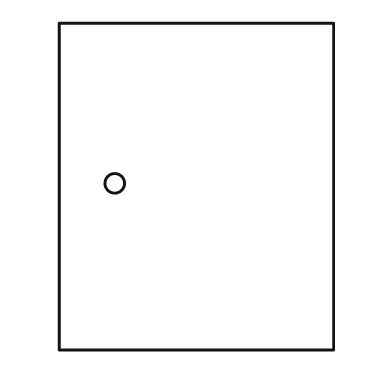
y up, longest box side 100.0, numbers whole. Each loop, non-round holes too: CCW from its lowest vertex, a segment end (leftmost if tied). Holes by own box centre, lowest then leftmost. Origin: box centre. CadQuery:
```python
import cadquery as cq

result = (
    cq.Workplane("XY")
    .moveTo(-42.0, -50.0)
    .lineTo(42.0, -50.0)
    .lineTo(42.0, 50.0)
    .lineTo(-42.0, 50.0)
    .close()
    .moveTo(-25.0, 1.0)
    .circle(3.0)
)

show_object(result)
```